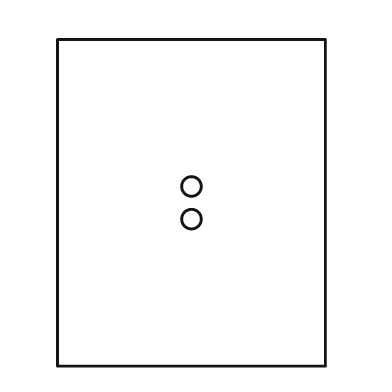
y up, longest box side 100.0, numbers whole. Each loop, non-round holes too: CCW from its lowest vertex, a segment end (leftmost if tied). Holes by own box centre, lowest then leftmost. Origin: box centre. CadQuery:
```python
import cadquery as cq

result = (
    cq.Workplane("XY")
    .moveTo(-41.0, -50.0)
    .lineTo(41.0, -50.0)
    .lineTo(41.0, 50.0)
    .lineTo(-41.0, 50.0)
    .close()
    .moveTo(0.0, -5.0)
    .circle(3.0)
    .moveTo(0.0, 5.0)
    .circle(3.0)
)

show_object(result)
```